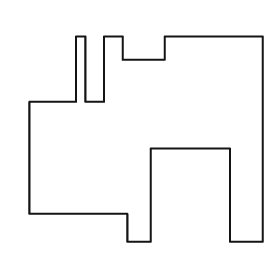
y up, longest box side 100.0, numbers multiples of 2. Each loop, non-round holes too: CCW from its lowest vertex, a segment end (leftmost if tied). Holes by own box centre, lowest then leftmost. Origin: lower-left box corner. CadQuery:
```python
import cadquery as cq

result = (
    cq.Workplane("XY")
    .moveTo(42.0, 0.0)
    .lineTo(52.0, 0.0)
    .lineTo(52.0, 40.0)
    .lineTo(86.0, 40.0)
    .lineTo(86.0, 0.0)
    .lineTo(100.0, 0.0)
    .lineTo(100.0, 88.0)
    .lineTo(58.0, 88.0)
    .lineTo(58.0, 78.0)
    .lineTo(40.0, 78.0)
    .lineTo(40.0, 88.0)
    .lineTo(32.0, 88.0)
    .lineTo(32.0, 60.0)
    .lineTo(24.0, 60.0)
    .lineTo(24.0, 88.0)
    .lineTo(20.0, 88.0)
    .lineTo(20.0, 60.0)
    .lineTo(0.0, 60.0)
    .lineTo(0.0, 12.0)
    .lineTo(42.0, 12.0)
    .close()
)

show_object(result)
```